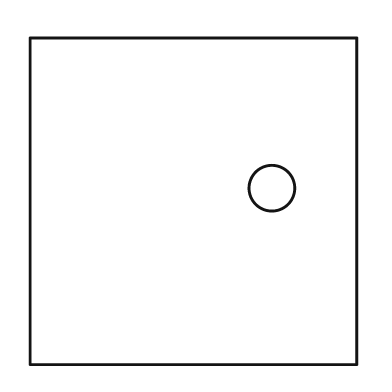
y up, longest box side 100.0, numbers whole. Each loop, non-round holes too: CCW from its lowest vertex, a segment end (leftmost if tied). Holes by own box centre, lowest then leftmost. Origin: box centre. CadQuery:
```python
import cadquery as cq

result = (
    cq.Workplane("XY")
    .moveTo(-50.0, -50.0)
    .lineTo(50.0, -50.0)
    .lineTo(50.0, 50.0)
    .lineTo(-50.0, 50.0)
    .close()
    .moveTo(24.0, 4.0)
    .circle(7.0)
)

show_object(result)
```